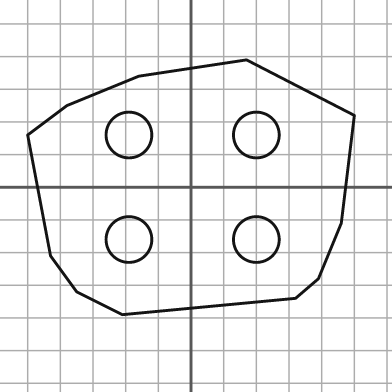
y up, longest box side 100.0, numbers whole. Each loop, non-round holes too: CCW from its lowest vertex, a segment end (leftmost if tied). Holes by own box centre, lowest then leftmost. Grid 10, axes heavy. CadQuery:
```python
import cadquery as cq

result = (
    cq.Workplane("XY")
    .moveTo(-21.0, -39.0)
    .lineTo(32.0, -34.0)
    .lineTo(39.0, -28.0)
    .lineTo(46.0, -11.0)
    .lineTo(50.0, 22.0)
    .lineTo(17.0, 39.0)
    .lineTo(-16.0, 34.0)
    .lineTo(-38.0, 25.0)
    .lineTo(-50.0, 16.0)
    .lineTo(-43.0, -21.0)
    .lineTo(-35.0, -32.0)
    .close()
    .moveTo(-19.0, -16.0)
    .circle(7.0)
    .moveTo(20.0, -16.0)
    .circle(7.0)
    .moveTo(-19.0, 16.0)
    .circle(7.0)
    .moveTo(20.0, 16.0)
    .circle(7.0)
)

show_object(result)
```